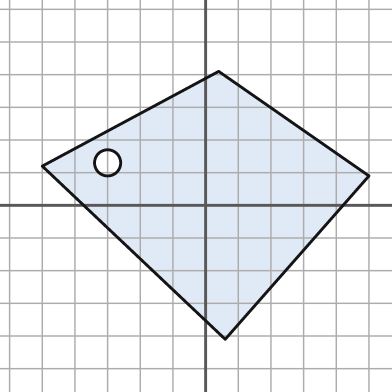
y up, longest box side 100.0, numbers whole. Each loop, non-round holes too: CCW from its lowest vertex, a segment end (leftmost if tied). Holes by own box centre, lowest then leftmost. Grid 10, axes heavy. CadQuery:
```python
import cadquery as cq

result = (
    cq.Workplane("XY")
    .moveTo(6.0, -41.0)
    .lineTo(50.0, 9.0)
    .lineTo(4.0, 41.0)
    .lineTo(-50.0, 12.0)
    .close()
    .moveTo(-30.0, 13.0)
    .circle(4.0)
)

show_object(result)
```